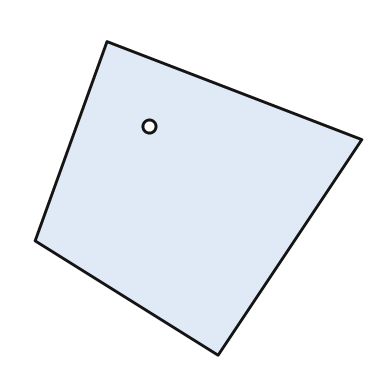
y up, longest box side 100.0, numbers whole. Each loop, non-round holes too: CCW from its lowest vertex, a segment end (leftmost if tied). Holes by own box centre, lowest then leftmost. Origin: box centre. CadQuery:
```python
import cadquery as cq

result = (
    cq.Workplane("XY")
    .moveTo(6.0, -48.0)
    .lineTo(50.0, 18.0)
    .lineTo(-28.0, 48.0)
    .lineTo(-50.0, -13.0)
    .close()
    .moveTo(-15.0, 22.0)
    .circle(2.0)
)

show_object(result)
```